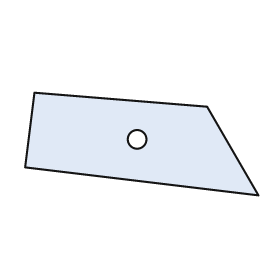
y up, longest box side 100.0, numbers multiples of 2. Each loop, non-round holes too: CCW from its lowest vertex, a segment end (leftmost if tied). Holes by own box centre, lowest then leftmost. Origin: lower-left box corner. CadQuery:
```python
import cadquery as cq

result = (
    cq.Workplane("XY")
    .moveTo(100.0, 0.0)
    .lineTo(78.0, 38.0)
    .lineTo(4.0, 44.0)
    .lineTo(0.0, 12.0)
    .close()
    .moveTo(48.0, 24.0)
    .circle(4.0)
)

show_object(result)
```